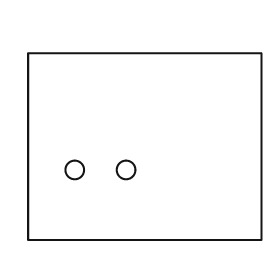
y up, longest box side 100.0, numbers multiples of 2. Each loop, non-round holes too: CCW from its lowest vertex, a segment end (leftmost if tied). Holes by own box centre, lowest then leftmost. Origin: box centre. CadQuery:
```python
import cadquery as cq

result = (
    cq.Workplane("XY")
    .moveTo(-50.0, -40.0)
    .lineTo(50.0, -40.0)
    .lineTo(50.0, 40.0)
    .lineTo(-50.0, 40.0)
    .close()
    .moveTo(-30.0, -10.0)
    .circle(4.0)
    .moveTo(-8.0, -10.0)
    .circle(4.0)
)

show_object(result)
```